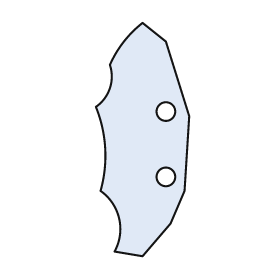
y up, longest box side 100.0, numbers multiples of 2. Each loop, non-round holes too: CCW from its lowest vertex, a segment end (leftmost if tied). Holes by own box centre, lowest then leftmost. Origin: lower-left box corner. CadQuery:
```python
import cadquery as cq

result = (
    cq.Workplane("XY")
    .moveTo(20.0, 0.0)
    .lineTo(32.0, 14.0)
    .lineTo(38.0, 28.0)
    .lineTo(40.0, 60.0)
    .lineTo(30.0, 92.0)
    .lineTo(20.0, 100.0)
    .threePointArc((12.0, 92.0), (6.0, 82.0))
    .threePointArc((6.0, 72.0), (0.0, 64.0))
    .threePointArc((4.0, 46.0), (2.0, 28.0))
    .threePointArc((10.0, 16.0), (8.0, 2.0))
    .close()
    .moveTo(30.0, 34.0)
    .circle(4.0)
    .moveTo(30.0, 62.0)
    .circle(4.0)
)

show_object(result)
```